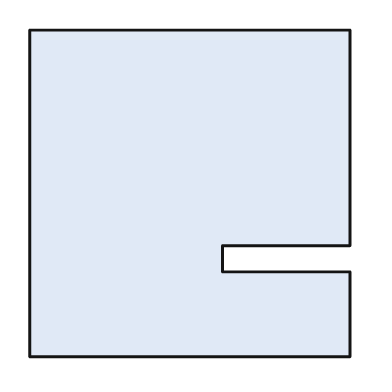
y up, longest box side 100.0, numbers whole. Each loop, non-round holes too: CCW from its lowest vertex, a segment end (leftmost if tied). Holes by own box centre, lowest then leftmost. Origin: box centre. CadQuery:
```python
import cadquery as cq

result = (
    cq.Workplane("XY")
    .moveTo(-49.0, -50.0)
    .lineTo(49.0, -50.0)
    .lineTo(49.0, -24.0)
    .lineTo(10.0, -24.0)
    .lineTo(10.0, -16.0)
    .lineTo(49.0, -16.0)
    .lineTo(49.0, 50.0)
    .lineTo(-49.0, 50.0)
    .close()
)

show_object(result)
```